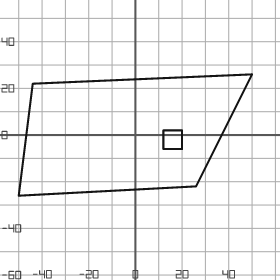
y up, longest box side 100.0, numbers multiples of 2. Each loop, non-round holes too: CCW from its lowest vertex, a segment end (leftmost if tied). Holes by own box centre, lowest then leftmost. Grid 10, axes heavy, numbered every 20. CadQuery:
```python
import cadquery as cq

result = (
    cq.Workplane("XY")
    .moveTo(-50.0, -26.0)
    .lineTo(26.0, -22.0)
    .lineTo(50.0, 26.0)
    .lineTo(-44.0, 22.0)
    .close()
    .moveTo(12.0, -6.0)
    .lineTo(20.0, -6.0)
    .lineTo(20.0, 2.0)
    .lineTo(12.0, 2.0)
    .close()
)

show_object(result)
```